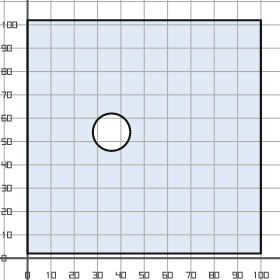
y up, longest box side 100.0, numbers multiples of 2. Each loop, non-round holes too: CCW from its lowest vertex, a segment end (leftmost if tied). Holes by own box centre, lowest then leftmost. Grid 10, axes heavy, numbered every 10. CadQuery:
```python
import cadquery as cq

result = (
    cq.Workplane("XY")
    .moveTo(0.0, 2.0)
    .lineTo(100.0, 2.0)
    .lineTo(100.0, 102.0)
    .lineTo(0.0, 102.0)
    .close()
    .moveTo(36.0, 54.0)
    .circle(8.0)
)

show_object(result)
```